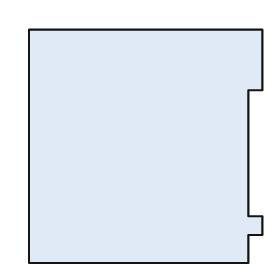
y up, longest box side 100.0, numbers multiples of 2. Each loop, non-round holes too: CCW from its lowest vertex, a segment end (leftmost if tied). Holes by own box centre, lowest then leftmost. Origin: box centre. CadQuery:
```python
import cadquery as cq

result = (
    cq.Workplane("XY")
    .moveTo(-50.0, -50.0)
    .lineTo(44.0, -50.0)
    .lineTo(44.0, -38.0)
    .lineTo(50.0, -38.0)
    .lineTo(50.0, -30.0)
    .lineTo(44.0, -30.0)
    .lineTo(44.0, 24.0)
    .lineTo(50.0, 24.0)
    .lineTo(50.0, 50.0)
    .lineTo(-50.0, 50.0)
    .close()
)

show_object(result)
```